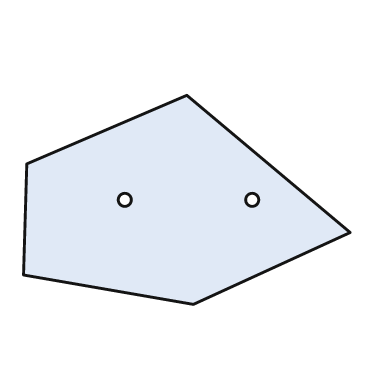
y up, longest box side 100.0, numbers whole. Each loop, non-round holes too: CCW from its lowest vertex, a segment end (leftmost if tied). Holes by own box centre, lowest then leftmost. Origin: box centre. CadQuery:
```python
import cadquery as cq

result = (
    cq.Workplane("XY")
    .moveTo(2.0, -32.0)
    .lineTo(50.0, -10.0)
    .lineTo(0.0, 32.0)
    .lineTo(-49.0, 11.0)
    .lineTo(-50.0, -23.0)
    .close()
    .moveTo(-19.0, 0.0)
    .circle(2.0)
    .moveTo(20.0, 0.0)
    .circle(2.0)
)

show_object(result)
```